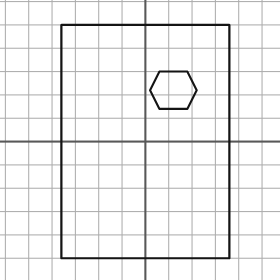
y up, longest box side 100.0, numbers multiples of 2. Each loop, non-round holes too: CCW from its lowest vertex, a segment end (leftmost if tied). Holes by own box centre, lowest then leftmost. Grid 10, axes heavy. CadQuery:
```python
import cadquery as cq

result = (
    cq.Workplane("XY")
    .moveTo(-36.0, -50.0)
    .lineTo(36.0, -50.0)
    .lineTo(36.0, 50.0)
    .lineTo(-36.0, 50.0)
    .close()
    .moveTo(6.0, 14.0)
    .lineTo(18.0, 14.0)
    .lineTo(22.0, 22.0)
    .lineTo(18.0, 30.0)
    .lineTo(6.0, 30.0)
    .lineTo(2.0, 22.0)
    .close()
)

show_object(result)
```